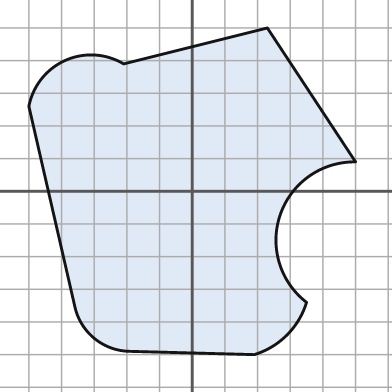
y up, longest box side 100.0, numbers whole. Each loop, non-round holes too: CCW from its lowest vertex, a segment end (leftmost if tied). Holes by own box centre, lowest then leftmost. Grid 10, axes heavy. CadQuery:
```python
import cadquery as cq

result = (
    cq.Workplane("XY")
    .moveTo(19.0, -50.0)
    .threePointArc((29.0, -44.0), (35.0, -34.0))
    .threePointArc((27.0, -7.0), (50.0, 9.0))
    .lineTo(23.0, 50.0)
    .lineTo(-21.0, 39.0)
    .threePointArc((-39.0, 40.0), (-50.0, 26.0))
    .lineTo(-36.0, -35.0)
    .threePointArc((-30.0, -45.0), (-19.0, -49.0))
    .close()
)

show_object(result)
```